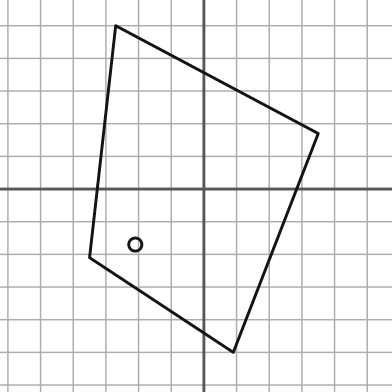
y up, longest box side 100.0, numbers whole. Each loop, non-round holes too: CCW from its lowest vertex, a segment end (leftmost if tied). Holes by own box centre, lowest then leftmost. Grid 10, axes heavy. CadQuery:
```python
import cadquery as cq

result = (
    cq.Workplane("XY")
    .moveTo(9.0, -50.0)
    .lineTo(35.0, 17.0)
    .lineTo(-27.0, 50.0)
    .lineTo(-35.0, -21.0)
    .close()
    .moveTo(-21.0, -17.0)
    .circle(2.0)
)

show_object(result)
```